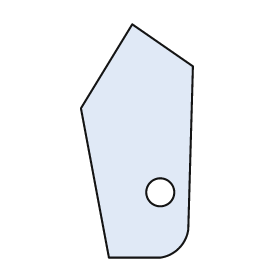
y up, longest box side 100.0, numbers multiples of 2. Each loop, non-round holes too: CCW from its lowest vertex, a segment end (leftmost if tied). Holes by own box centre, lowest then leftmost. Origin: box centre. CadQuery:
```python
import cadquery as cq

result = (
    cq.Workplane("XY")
    .moveTo(-12.0, -50.0)
    .lineTo(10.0, -50.0)
    .threePointArc((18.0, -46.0), (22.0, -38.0))
    .lineTo(24.0, 32.0)
    .lineTo(-2.0, 50.0)
    .lineTo(-24.0, 14.0)
    .close()
    .moveTo(10.0, -22.0)
    .circle(6.0)
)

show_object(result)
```